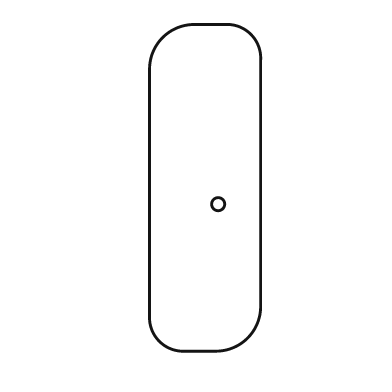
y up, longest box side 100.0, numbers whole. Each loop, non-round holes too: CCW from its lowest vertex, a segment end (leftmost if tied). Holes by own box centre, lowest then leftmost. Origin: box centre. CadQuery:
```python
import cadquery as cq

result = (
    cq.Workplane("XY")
    .moveTo(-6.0, -50.0)
    .lineTo(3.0, -50.0)
    .threePointArc((13.0, -46.0), (17.0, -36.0))
    .lineTo(17.0, 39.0)
    .threePointArc((14.0, 47.0), (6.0, 50.0))
    .lineTo(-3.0, 50.0)
    .threePointArc((-13.0, 46.0), (-17.0, 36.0))
    .lineTo(-17.0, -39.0)
    .threePointArc((-14.0, -47.0), (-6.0, -50.0))
    .close()
    .moveTo(4.0, -5.0)
    .circle(2.0)
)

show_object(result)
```